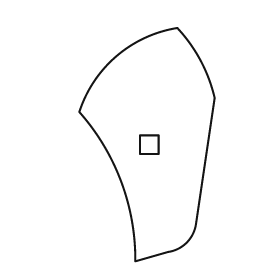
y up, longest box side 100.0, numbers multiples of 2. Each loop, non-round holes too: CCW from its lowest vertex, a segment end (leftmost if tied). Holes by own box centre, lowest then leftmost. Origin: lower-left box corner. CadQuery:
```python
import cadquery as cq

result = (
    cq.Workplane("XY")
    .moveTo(24.0, 0.0)
    .lineTo(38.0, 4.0)
    .threePointArc((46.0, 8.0), (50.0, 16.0))
    .lineTo(58.0, 70.0)
    .threePointArc((52.0, 86.0), (42.0, 100.0))
    .threePointArc((16.0, 88.0), (0.0, 64.0))
    .threePointArc((18.0, 34.0), (24.0, 0.0))
    .close()
    .moveTo(26.0, 46.0)
    .lineTo(34.0, 46.0)
    .lineTo(34.0, 54.0)
    .lineTo(26.0, 54.0)
    .close()
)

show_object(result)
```